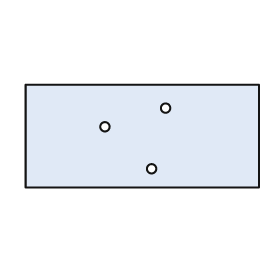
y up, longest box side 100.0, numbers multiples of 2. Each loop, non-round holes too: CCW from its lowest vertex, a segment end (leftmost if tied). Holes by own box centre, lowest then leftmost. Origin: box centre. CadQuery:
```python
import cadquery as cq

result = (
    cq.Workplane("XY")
    .moveTo(-50.0, -22.0)
    .lineTo(50.0, -22.0)
    .lineTo(50.0, 22.0)
    .lineTo(-50.0, 22.0)
    .close()
    .moveTo(4.0, -14.0)
    .circle(2.0)
    .moveTo(-16.0, 4.0)
    .circle(2.0)
    .moveTo(10.0, 12.0)
    .circle(2.0)
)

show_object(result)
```